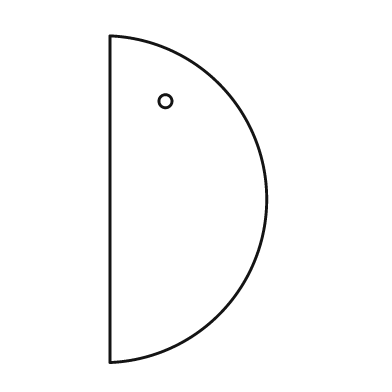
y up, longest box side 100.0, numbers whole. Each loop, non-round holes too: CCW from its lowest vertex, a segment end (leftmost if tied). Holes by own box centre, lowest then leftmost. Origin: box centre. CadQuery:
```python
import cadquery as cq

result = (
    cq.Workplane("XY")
    .moveTo(-24.0, -50.0)
    .threePointArc((24.0, 0.0), (-24.0, 50.0))
    .close()
    .moveTo(-7.0, 30.0)
    .circle(2.0)
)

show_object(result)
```